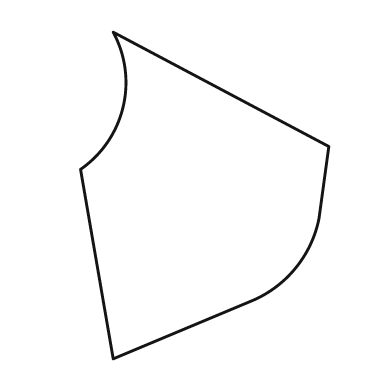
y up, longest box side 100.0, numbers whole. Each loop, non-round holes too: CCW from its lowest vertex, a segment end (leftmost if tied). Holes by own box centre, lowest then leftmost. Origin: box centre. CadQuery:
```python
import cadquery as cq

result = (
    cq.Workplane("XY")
    .moveTo(-28.0, -50.0)
    .lineTo(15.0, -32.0)
    .threePointArc((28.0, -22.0), (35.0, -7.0))
    .lineTo(38.0, 15.0)
    .lineTo(-28.0, 50.0)
    .threePointArc((-25.0, 27.0), (-38.0, 8.0))
    .close()
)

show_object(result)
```